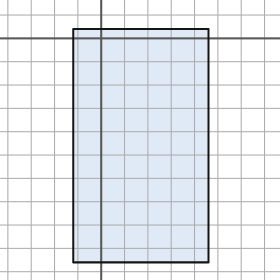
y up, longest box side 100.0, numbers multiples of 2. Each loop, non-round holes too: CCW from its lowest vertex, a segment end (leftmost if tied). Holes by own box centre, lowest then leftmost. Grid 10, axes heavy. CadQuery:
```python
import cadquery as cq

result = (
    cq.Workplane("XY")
    .moveTo(-12.0, -96.0)
    .lineTo(46.0, -96.0)
    .lineTo(46.0, 4.0)
    .lineTo(-12.0, 4.0)
    .close()
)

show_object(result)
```